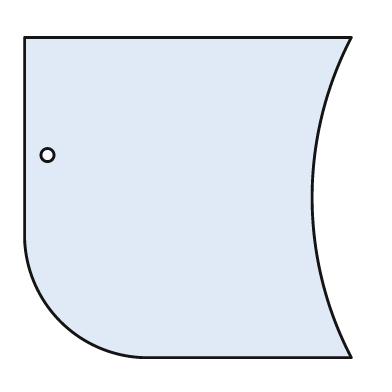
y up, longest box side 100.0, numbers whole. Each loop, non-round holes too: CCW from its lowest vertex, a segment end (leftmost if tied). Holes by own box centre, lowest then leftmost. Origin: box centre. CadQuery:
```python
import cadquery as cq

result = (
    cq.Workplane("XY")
    .moveTo(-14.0, -49.0)
    .lineTo(50.0, -49.0)
    .threePointArc((38.0, 0.0), (50.0, 49.0))
    .lineTo(-50.0, 49.0)
    .lineTo(-50.0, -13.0)
    .threePointArc((-39.0, -38.0), (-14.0, -49.0))
    .close()
    .moveTo(-43.0, 13.0)
    .circle(2.0)
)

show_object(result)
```